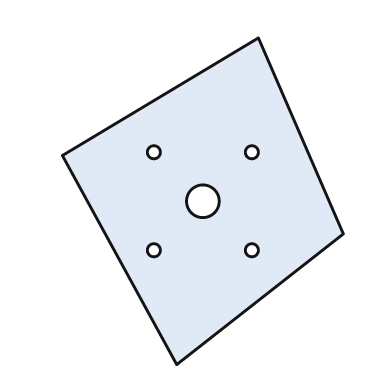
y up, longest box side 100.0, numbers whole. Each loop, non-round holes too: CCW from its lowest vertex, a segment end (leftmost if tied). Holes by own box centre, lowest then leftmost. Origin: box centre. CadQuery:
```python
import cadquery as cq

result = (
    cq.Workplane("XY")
    .moveTo(-8.0, -50.0)
    .lineTo(43.0, -10.0)
    .lineTo(17.0, 50.0)
    .lineTo(-43.0, 14.0)
    .close()
    .moveTo(-15.0, -15.0)
    .circle(2.0)
    .moveTo(15.0, -15.0)
    .circle(2.0)
    .moveTo(0.0, 0.0)
    .circle(5.0)
    .moveTo(-15.0, 15.0)
    .circle(2.0)
    .moveTo(15.0, 15.0)
    .circle(2.0)
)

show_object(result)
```